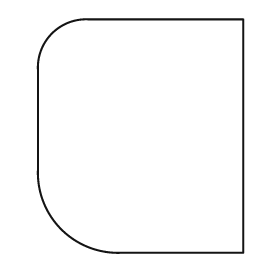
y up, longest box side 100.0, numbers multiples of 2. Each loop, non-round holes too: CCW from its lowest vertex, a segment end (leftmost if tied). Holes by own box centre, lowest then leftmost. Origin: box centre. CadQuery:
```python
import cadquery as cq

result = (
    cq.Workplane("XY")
    .moveTo(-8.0, -50.0)
    .lineTo(44.0, -50.0)
    .lineTo(44.0, 50.0)
    .lineTo(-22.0, 50.0)
    .threePointArc((-38.0, 44.0), (-44.0, 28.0))
    .lineTo(-44.0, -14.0)
    .threePointArc((-34.0, -40.0), (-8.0, -50.0))
    .close()
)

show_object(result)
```